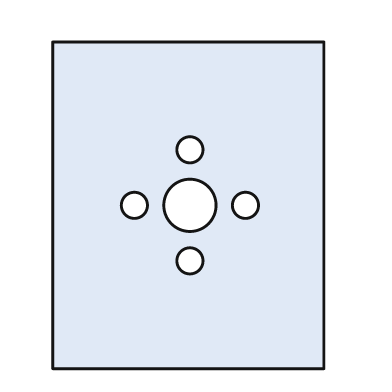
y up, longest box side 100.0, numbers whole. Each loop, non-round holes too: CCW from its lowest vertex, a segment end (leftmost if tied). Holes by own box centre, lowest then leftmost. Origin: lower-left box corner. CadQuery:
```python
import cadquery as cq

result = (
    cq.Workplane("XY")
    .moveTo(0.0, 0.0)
    .lineTo(83.0, 0.0)
    .lineTo(83.0, 100.0)
    .lineTo(0.0, 100.0)
    .close()
    .moveTo(42.0, 33.0)
    .circle(4.0)
    .moveTo(25.0, 50.0)
    .circle(4.0)
    .moveTo(42.0, 50.0)
    .circle(8.0)
    .moveTo(59.0, 50.0)
    .circle(4.0)
    .moveTo(42.0, 67.0)
    .circle(4.0)
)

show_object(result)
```